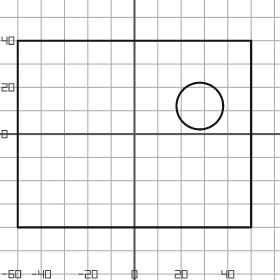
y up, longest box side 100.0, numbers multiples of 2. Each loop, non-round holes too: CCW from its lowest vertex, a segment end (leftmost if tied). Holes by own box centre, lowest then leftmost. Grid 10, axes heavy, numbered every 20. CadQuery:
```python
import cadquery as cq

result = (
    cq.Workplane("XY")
    .moveTo(-50.0, -40.0)
    .lineTo(50.0, -40.0)
    .lineTo(50.0, 40.0)
    .lineTo(-50.0, 40.0)
    .close()
    .moveTo(28.0, 12.0)
    .circle(10.0)
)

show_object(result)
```